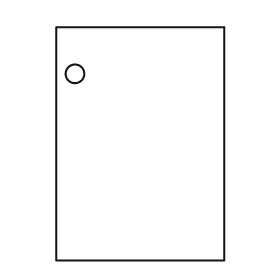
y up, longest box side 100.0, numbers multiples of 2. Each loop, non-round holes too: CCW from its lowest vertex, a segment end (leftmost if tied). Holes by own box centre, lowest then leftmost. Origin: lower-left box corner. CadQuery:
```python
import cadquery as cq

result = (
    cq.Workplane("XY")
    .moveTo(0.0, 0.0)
    .lineTo(72.0, 0.0)
    .lineTo(72.0, 100.0)
    .lineTo(0.0, 100.0)
    .close()
    .moveTo(8.0, 80.0)
    .circle(4.0)
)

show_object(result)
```